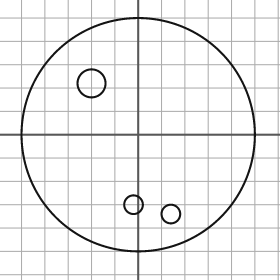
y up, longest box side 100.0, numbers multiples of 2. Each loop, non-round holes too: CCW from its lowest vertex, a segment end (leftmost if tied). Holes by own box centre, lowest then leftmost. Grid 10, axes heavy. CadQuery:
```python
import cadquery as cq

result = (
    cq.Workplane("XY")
    .moveTo(0.0, 0.0)
    .circle(50.0)
    .moveTo(14.0, -34.0)
    .circle(4.0)
    .moveTo(-2.0, -30.0)
    .circle(4.0)
    .moveTo(-20.0, 22.0)
    .circle(6.0)
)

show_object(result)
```